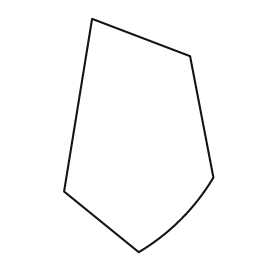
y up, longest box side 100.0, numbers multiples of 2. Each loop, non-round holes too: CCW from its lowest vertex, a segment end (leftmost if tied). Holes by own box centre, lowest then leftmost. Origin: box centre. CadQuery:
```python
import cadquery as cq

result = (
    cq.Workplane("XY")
    .moveTo(0.0, -50.0)
    .threePointArc((18.0, -36.0), (32.0, -18.0))
    .lineTo(22.0, 34.0)
    .lineTo(-20.0, 50.0)
    .lineTo(-32.0, -24.0)
    .close()
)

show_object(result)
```